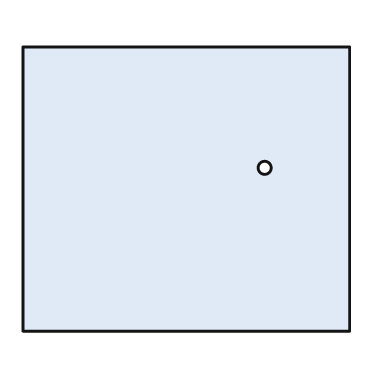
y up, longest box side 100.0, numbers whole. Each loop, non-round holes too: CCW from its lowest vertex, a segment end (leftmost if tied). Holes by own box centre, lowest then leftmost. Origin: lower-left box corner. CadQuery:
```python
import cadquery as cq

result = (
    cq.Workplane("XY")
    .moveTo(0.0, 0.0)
    .lineTo(100.0, 0.0)
    .lineTo(100.0, 87.0)
    .lineTo(0.0, 87.0)
    .close()
    .moveTo(74.0, 50.0)
    .circle(2.0)
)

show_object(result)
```